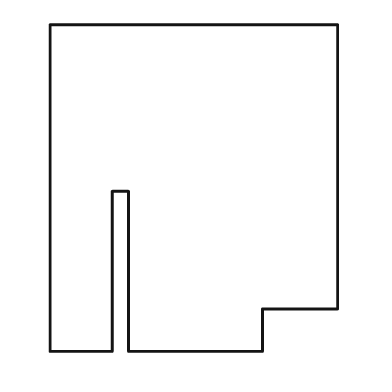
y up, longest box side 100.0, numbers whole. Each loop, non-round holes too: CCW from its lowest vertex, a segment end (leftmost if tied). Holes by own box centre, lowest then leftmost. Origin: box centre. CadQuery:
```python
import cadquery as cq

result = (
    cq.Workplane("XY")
    .moveTo(-44.0, -50.0)
    .lineTo(-25.0, -50.0)
    .lineTo(-25.0, -1.0)
    .lineTo(-20.0, -1.0)
    .lineTo(-20.0, -50.0)
    .lineTo(21.0, -50.0)
    .lineTo(21.0, -37.0)
    .lineTo(44.0, -37.0)
    .lineTo(44.0, 50.0)
    .lineTo(-44.0, 50.0)
    .close()
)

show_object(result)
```